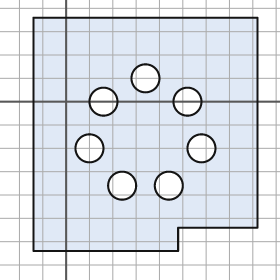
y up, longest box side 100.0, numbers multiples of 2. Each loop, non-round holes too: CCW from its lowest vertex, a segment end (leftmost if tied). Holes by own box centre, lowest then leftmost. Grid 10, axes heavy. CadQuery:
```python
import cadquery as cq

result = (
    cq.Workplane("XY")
    .moveTo(-14.0, -64.0)
    .lineTo(48.0, -64.0)
    .lineTo(48.0, -54.0)
    .lineTo(82.0, -54.0)
    .lineTo(82.0, 36.0)
    .lineTo(-14.0, 36.0)
    .close()
    .moveTo(24.0, -36.0)
    .circle(6.0)
    .moveTo(44.0, -36.0)
    .circle(6.0)
    .moveTo(10.0, -20.0)
    .circle(6.0)
    .moveTo(58.0, -20.0)
    .circle(6.0)
    .moveTo(16.0, 0.0)
    .circle(6.0)
    .moveTo(52.0, 0.0)
    .circle(6.0)
    .moveTo(34.0, 10.0)
    .circle(6.0)
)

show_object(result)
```